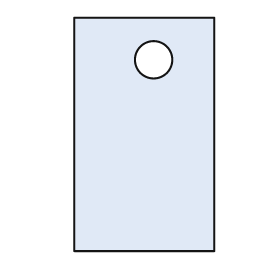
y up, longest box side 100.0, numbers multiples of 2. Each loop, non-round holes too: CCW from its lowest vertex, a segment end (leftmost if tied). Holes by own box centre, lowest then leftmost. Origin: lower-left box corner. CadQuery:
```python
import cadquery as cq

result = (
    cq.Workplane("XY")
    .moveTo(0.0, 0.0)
    .lineTo(60.0, 0.0)
    .lineTo(60.0, 100.0)
    .lineTo(0.0, 100.0)
    .close()
    .moveTo(34.0, 82.0)
    .circle(8.0)
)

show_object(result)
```